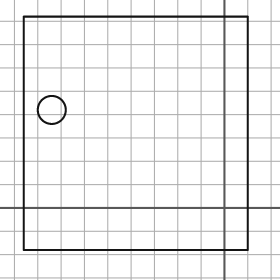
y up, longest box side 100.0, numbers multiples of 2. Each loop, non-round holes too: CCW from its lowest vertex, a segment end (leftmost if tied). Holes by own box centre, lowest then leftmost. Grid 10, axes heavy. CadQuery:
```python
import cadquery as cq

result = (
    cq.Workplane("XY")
    .moveTo(-86.0, -18.0)
    .lineTo(10.0, -18.0)
    .lineTo(10.0, 82.0)
    .lineTo(-86.0, 82.0)
    .close()
    .moveTo(-74.0, 42.0)
    .circle(6.0)
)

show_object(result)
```